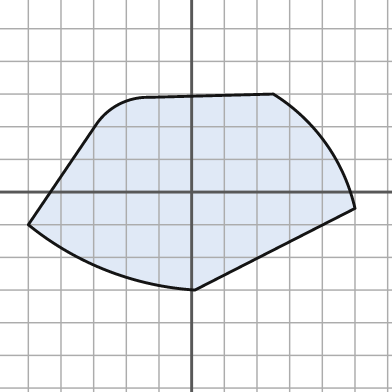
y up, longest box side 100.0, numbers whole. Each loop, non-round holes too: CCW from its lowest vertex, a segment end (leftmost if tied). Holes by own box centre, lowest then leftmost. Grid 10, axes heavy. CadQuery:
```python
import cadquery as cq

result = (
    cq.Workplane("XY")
    .moveTo(1.0, -30.0)
    .lineTo(50.0, -5.0)
    .threePointArc((41.0, 15.0), (25.0, 30.0))
    .lineTo(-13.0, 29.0)
    .threePointArc((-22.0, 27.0), (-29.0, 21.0))
    .lineTo(-50.0, -10.0)
    .threePointArc((-26.0, -24.0), (1.0, -30.0))
    .close()
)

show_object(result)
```